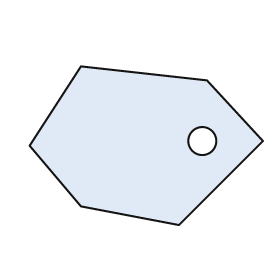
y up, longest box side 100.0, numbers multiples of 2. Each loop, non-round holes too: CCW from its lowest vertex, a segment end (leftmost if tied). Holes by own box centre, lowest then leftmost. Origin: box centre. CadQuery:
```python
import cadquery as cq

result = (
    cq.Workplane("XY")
    .moveTo(14.0, -34.0)
    .lineTo(50.0, 2.0)
    .lineTo(26.0, 28.0)
    .lineTo(-28.0, 34.0)
    .lineTo(-50.0, 0.0)
    .lineTo(-28.0, -26.0)
    .close()
    .moveTo(24.0, 2.0)
    .circle(6.0)
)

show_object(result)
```